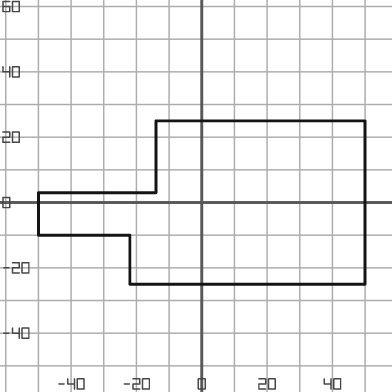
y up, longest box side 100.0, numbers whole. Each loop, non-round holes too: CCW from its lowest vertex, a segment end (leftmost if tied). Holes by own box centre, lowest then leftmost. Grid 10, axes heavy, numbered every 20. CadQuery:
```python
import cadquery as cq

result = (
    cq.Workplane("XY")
    .moveTo(-22.0, -25.0)
    .lineTo(50.0, -25.0)
    .lineTo(50.0, 25.0)
    .lineTo(-14.0, 25.0)
    .lineTo(-14.0, 3.0)
    .lineTo(-50.0, 3.0)
    .lineTo(-50.0, -10.0)
    .lineTo(-22.0, -10.0)
    .close()
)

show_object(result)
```